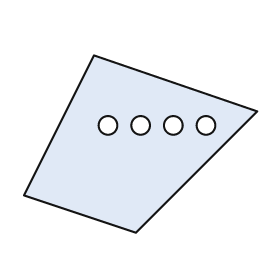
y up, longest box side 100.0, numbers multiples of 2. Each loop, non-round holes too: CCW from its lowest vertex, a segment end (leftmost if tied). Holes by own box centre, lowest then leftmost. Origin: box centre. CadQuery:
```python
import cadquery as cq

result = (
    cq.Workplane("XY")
    .moveTo(-2.0, -38.0)
    .lineTo(50.0, 14.0)
    .lineTo(-20.0, 38.0)
    .lineTo(-50.0, -22.0)
    .close()
    .moveTo(-14.0, 8.0)
    .circle(4.0)
    .moveTo(0.0, 8.0)
    .circle(4.0)
    .moveTo(14.0, 8.0)
    .circle(4.0)
    .moveTo(28.0, 8.0)
    .circle(4.0)
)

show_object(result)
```